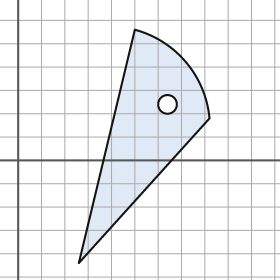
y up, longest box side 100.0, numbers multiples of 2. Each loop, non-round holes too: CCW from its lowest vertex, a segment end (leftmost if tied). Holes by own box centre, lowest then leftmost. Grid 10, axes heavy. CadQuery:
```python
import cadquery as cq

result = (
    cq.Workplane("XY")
    .moveTo(26.0, -44.0)
    .lineTo(82.0, 18.0)
    .threePointArc((72.0, 42.0), (50.0, 56.0))
    .close()
    .moveTo(64.0, 24.0)
    .circle(4.0)
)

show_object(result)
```